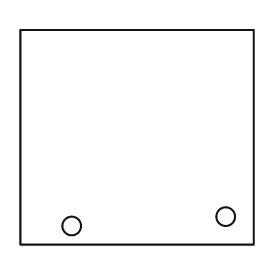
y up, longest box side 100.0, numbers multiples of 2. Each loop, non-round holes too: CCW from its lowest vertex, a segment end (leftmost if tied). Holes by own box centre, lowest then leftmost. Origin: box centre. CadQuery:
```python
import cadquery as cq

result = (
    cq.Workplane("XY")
    .moveTo(-50.0, -46.0)
    .lineTo(50.0, -46.0)
    .lineTo(50.0, 46.0)
    .lineTo(-50.0, 46.0)
    .close()
    .moveTo(-28.0, -38.0)
    .circle(4.0)
    .moveTo(38.0, -34.0)
    .circle(4.0)
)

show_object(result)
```